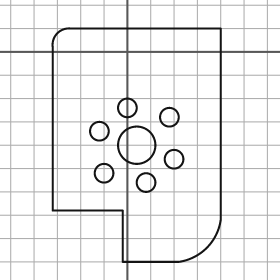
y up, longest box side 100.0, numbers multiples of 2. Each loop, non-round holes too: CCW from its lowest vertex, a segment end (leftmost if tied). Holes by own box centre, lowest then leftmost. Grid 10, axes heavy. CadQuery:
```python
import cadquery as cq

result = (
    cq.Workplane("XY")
    .moveTo(-2.0, -90.0)
    .lineTo(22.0, -90.0)
    .threePointArc((34.0, -84.0), (40.0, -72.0))
    .lineTo(40.0, 10.0)
    .lineTo(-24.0, 10.0)
    .threePointArc((-30.0, 8.0), (-32.0, 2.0))
    .lineTo(-32.0, -68.0)
    .lineTo(-2.0, -68.0)
    .close()
    .moveTo(8.0, -56.0)
    .circle(4.0)
    .moveTo(-10.0, -52.0)
    .circle(4.0)
    .moveTo(20.0, -46.0)
    .circle(4.0)
    .moveTo(4.0, -40.0)
    .circle(8.0)
    .moveTo(-12.0, -34.0)
    .circle(4.0)
    .moveTo(18.0, -28.0)
    .circle(4.0)
    .moveTo(0.0, -24.0)
    .circle(4.0)
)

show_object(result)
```